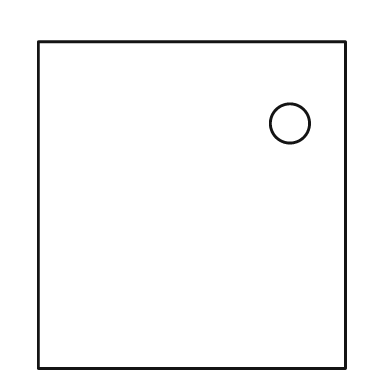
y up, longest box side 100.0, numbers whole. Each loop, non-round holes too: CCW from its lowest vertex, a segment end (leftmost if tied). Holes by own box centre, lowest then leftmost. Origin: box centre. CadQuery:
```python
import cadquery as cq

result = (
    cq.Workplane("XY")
    .moveTo(-47.0, -50.0)
    .lineTo(47.0, -50.0)
    .lineTo(47.0, 50.0)
    .lineTo(-47.0, 50.0)
    .close()
    .moveTo(30.0, 25.0)
    .circle(6.0)
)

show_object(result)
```